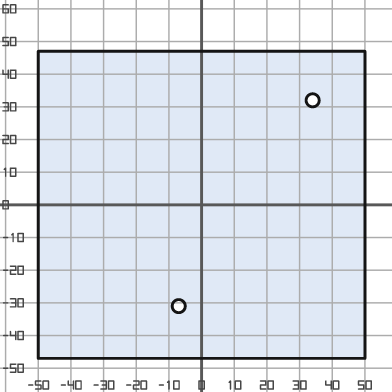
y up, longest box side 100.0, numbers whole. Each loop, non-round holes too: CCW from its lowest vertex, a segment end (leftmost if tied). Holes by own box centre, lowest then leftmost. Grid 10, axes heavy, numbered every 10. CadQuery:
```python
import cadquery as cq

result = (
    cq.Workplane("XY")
    .moveTo(-50.0, -47.0)
    .lineTo(50.0, -47.0)
    .lineTo(50.0, 47.0)
    .lineTo(-50.0, 47.0)
    .close()
    .moveTo(-7.0, -31.0)
    .circle(2.0)
    .moveTo(34.0, 32.0)
    .circle(2.0)
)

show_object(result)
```